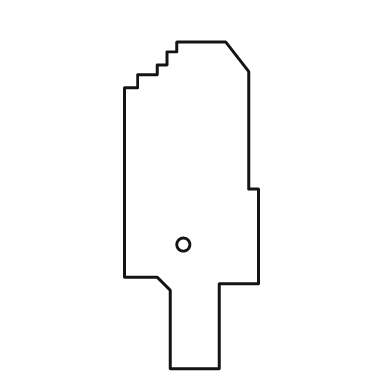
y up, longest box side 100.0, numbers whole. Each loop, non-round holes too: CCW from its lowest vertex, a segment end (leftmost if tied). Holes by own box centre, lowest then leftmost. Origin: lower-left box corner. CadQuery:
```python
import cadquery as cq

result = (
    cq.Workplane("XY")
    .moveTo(14.0, 0.0)
    .lineTo(29.0, 0.0)
    .lineTo(29.0, 26.0)
    .lineTo(41.0, 26.0)
    .lineTo(41.0, 55.0)
    .lineTo(38.0, 55.0)
    .lineTo(38.0, 91.0)
    .lineTo(31.0, 100.0)
    .lineTo(16.0, 100.0)
    .lineTo(16.0, 97.0)
    .lineTo(13.0, 97.0)
    .lineTo(13.0, 93.0)
    .lineTo(10.0, 93.0)
    .lineTo(10.0, 90.0)
    .lineTo(4.0, 90.0)
    .lineTo(4.0, 86.0)
    .lineTo(0.0, 86.0)
    .lineTo(0.0, 28.0)
    .lineTo(10.0, 28.0)
    .lineTo(14.0, 24.0)
    .close()
    .moveTo(18.0, 38.0)
    .circle(2.0)
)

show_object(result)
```